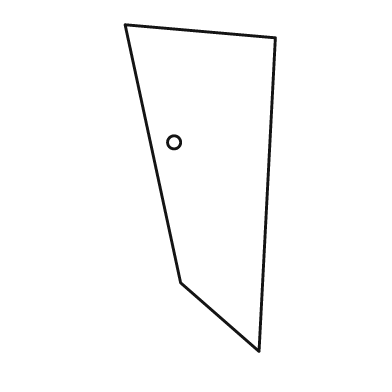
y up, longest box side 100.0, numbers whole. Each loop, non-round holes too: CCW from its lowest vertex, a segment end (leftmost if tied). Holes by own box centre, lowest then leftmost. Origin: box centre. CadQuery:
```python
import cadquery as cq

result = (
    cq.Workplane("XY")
    .moveTo(18.0, -50.0)
    .lineTo(23.0, 46.0)
    .lineTo(-23.0, 50.0)
    .lineTo(-6.0, -29.0)
    .close()
    .moveTo(-8.0, 14.0)
    .circle(2.0)
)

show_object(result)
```